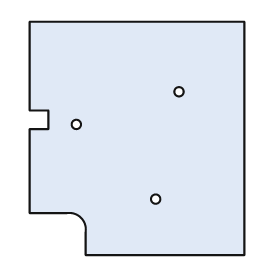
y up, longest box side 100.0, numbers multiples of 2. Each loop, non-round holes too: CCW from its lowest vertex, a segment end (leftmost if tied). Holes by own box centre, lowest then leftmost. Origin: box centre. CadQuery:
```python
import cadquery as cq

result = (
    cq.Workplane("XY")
    .moveTo(-22.0, -50.0)
    .lineTo(46.0, -50.0)
    .lineTo(46.0, 50.0)
    .lineTo(-46.0, 50.0)
    .lineTo(-46.0, 12.0)
    .lineTo(-38.0, 12.0)
    .lineTo(-38.0, 4.0)
    .lineTo(-46.0, 4.0)
    .lineTo(-46.0, -32.0)
    .lineTo(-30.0, -32.0)
    .threePointArc((-24.0, -34.0), (-22.0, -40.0))
    .close()
    .moveTo(8.0, -26.0)
    .circle(2.0)
    .moveTo(-26.0, 6.0)
    .circle(2.0)
    .moveTo(18.0, 20.0)
    .circle(2.0)
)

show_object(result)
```